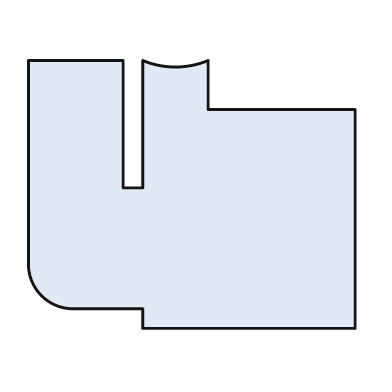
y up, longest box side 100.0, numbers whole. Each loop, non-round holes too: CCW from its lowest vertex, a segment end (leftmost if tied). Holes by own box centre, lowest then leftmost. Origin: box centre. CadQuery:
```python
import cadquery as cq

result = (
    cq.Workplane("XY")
    .moveTo(-15.0, -41.0)
    .lineTo(50.0, -41.0)
    .lineTo(50.0, 26.0)
    .lineTo(5.0, 26.0)
    .lineTo(5.0, 41.0)
    .threePointArc((-5.0, 39.0), (-15.0, 41.0))
    .lineTo(-15.0, 2.0)
    .lineTo(-21.0, 2.0)
    .lineTo(-21.0, 41.0)
    .lineTo(-50.0, 41.0)
    .lineTo(-50.0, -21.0)
    .threePointArc((-46.0, -31.0), (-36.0, -35.0))
    .lineTo(-15.0, -35.0)
    .close()
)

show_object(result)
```